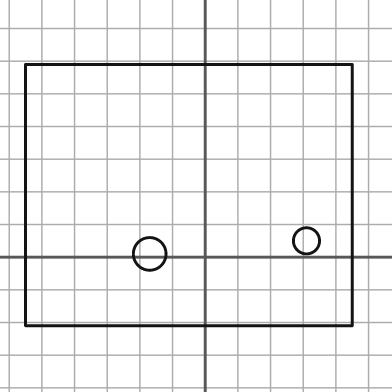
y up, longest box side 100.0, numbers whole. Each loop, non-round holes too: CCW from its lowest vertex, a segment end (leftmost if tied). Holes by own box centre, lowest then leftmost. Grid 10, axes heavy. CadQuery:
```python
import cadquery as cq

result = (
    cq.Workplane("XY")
    .moveTo(-55.0, -21.0)
    .lineTo(45.0, -21.0)
    .lineTo(45.0, 59.0)
    .lineTo(-55.0, 59.0)
    .close()
    .moveTo(-17.0, 1.0)
    .circle(5.0)
    .moveTo(31.0, 5.0)
    .circle(4.0)
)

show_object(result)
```